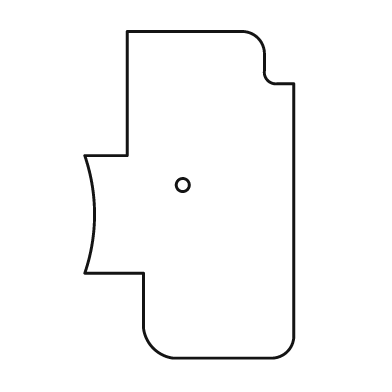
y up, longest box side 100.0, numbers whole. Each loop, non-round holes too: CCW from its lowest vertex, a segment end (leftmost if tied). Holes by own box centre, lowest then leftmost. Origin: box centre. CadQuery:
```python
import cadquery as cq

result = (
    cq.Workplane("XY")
    .moveTo(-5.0, -50.0)
    .lineTo(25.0, -50.0)
    .threePointArc((30.0, -48.0), (32.0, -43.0))
    .lineTo(32.0, 34.0)
    .lineTo(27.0, 34.0)
    .threePointArc((24.0, 35.0), (23.0, 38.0))
    .lineTo(23.0, 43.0)
    .threePointArc((21.0, 48.0), (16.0, 50.0))
    .lineTo(-19.0, 50.0)
    .lineTo(-19.0, 12.0)
    .lineTo(-32.0, 12.0)
    .threePointArc((-29.0, -6.0), (-32.0, -24.0))
    .lineTo(-14.0, -24.0)
    .lineTo(-14.0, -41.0)
    .threePointArc((-11.0, -47.0), (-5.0, -50.0))
    .close()
    .moveTo(-2.0, 3.0)
    .circle(2.0)
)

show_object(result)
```